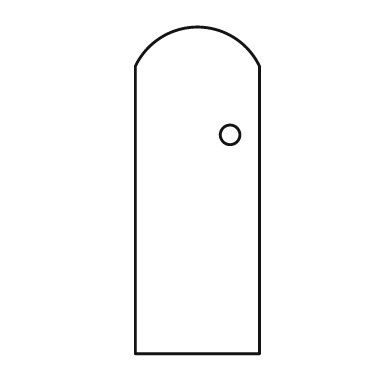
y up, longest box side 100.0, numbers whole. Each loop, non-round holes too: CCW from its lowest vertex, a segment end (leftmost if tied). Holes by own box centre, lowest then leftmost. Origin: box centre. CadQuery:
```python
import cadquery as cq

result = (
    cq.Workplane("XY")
    .moveTo(-19.0, -50.0)
    .lineTo(19.0, -50.0)
    .lineTo(19.0, 38.0)
    .threePointArc((0.0, 50.0), (-19.0, 38.0))
    .close()
    .moveTo(10.0, 17.0)
    .circle(3.0)
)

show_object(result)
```